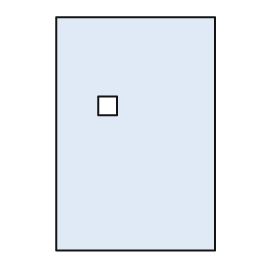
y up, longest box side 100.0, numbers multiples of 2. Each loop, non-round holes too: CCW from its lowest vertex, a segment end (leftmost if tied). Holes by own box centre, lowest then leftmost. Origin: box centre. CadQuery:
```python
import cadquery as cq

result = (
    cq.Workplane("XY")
    .moveTo(-34.0, -50.0)
    .lineTo(34.0, -50.0)
    .lineTo(34.0, 50.0)
    .lineTo(-34.0, 50.0)
    .close()
    .moveTo(-16.0, 8.0)
    .lineTo(-8.0, 8.0)
    .lineTo(-8.0, 16.0)
    .lineTo(-16.0, 16.0)
    .close()
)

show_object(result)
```